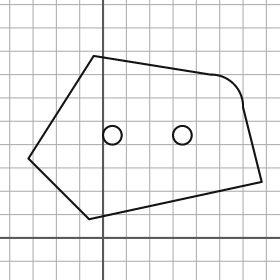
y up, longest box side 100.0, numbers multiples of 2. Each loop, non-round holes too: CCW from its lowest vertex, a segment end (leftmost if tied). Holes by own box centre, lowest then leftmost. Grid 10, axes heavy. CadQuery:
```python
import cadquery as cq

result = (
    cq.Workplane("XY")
    .moveTo(-6.0, 8.0)
    .lineTo(68.0, 24.0)
    .lineTo(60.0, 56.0)
    .threePointArc((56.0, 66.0), (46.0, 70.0))
    .lineTo(-4.0, 78.0)
    .lineTo(-32.0, 34.0)
    .close()
    .moveTo(4.0, 44.0)
    .circle(4.0)
    .moveTo(34.0, 44.0)
    .circle(4.0)
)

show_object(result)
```